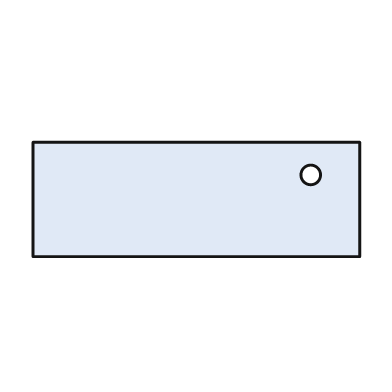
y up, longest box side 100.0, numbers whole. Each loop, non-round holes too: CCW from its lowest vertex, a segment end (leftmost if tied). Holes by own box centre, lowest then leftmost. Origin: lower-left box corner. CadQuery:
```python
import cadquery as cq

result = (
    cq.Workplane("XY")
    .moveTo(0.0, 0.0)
    .lineTo(100.0, 0.0)
    .lineTo(100.0, 35.0)
    .lineTo(0.0, 35.0)
    .close()
    .moveTo(85.0, 25.0)
    .circle(3.0)
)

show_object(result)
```